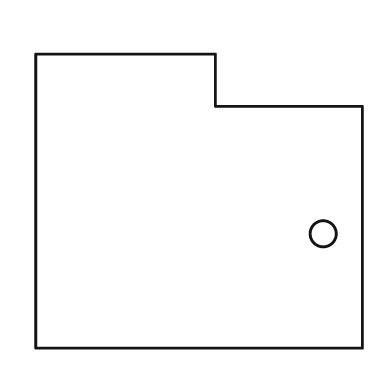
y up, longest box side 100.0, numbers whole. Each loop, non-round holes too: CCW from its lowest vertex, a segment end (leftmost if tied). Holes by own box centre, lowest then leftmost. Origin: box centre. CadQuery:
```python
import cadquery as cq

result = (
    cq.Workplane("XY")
    .moveTo(-50.0, -45.0)
    .lineTo(50.0, -45.0)
    .lineTo(50.0, 29.0)
    .lineTo(5.0, 29.0)
    .lineTo(5.0, 45.0)
    .lineTo(-50.0, 45.0)
    .close()
    .moveTo(38.0, -10.0)
    .circle(4.0)
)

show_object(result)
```